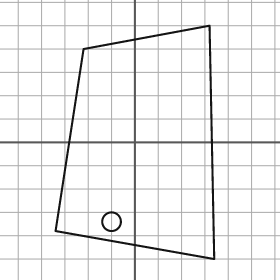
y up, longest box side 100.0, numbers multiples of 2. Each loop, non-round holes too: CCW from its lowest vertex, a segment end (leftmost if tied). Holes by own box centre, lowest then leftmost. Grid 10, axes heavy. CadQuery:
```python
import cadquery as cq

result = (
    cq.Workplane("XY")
    .moveTo(34.0, -50.0)
    .lineTo(32.0, 50.0)
    .lineTo(-22.0, 40.0)
    .lineTo(-34.0, -38.0)
    .close()
    .moveTo(-10.0, -34.0)
    .circle(4.0)
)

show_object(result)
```